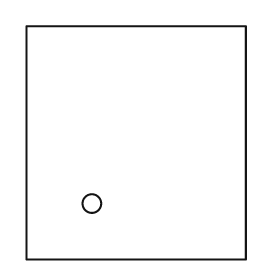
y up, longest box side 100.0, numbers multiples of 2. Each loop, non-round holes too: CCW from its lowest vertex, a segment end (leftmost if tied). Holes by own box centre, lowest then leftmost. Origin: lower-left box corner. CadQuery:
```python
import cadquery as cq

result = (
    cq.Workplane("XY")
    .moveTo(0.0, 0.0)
    .lineTo(94.0, 0.0)
    .lineTo(94.0, 100.0)
    .lineTo(0.0, 100.0)
    .close()
    .moveTo(28.0, 24.0)
    .circle(4.0)
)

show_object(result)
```